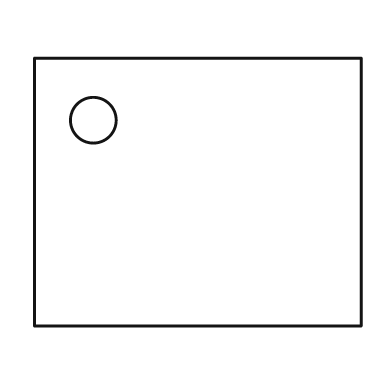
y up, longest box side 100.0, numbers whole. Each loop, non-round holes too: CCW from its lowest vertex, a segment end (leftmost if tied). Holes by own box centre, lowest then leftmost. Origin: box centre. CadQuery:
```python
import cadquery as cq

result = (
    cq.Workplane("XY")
    .moveTo(-50.0, -41.0)
    .lineTo(50.0, -41.0)
    .lineTo(50.0, 41.0)
    .lineTo(-50.0, 41.0)
    .close()
    .moveTo(-32.0, 22.0)
    .circle(7.0)
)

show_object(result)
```